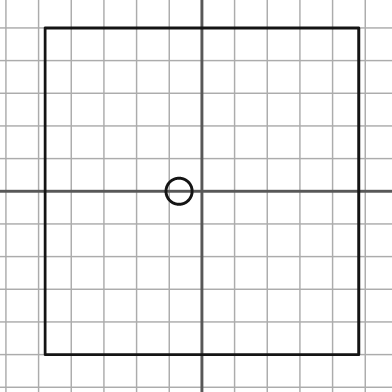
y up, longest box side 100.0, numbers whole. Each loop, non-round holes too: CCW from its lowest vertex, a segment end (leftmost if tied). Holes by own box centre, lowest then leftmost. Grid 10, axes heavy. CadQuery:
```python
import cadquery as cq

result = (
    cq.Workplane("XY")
    .moveTo(-48.0, -50.0)
    .lineTo(48.0, -50.0)
    .lineTo(48.0, 50.0)
    .lineTo(-48.0, 50.0)
    .close()
    .moveTo(-7.0, 0.0)
    .circle(4.0)
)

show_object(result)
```